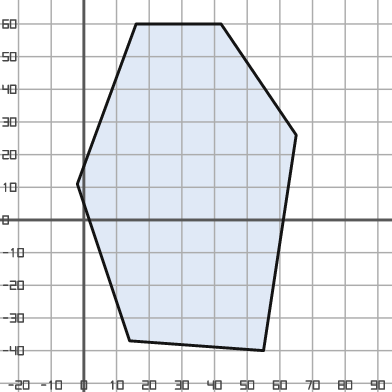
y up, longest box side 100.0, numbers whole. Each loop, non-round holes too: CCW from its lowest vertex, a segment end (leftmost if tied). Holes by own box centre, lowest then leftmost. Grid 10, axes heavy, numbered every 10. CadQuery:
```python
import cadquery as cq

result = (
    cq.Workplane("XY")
    .moveTo(55.0, -40.0)
    .lineTo(65.0, 26.0)
    .lineTo(42.0, 60.0)
    .lineTo(16.0, 60.0)
    .lineTo(-2.0, 11.0)
    .lineTo(14.0, -37.0)
    .close()
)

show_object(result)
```